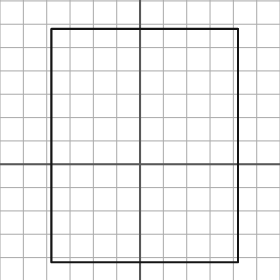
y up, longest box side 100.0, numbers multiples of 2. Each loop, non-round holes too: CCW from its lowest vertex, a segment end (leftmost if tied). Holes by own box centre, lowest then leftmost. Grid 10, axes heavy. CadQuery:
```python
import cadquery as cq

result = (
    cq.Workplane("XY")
    .moveTo(-38.0, -42.0)
    .lineTo(42.0, -42.0)
    .lineTo(42.0, 58.0)
    .lineTo(-38.0, 58.0)
    .close()
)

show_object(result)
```